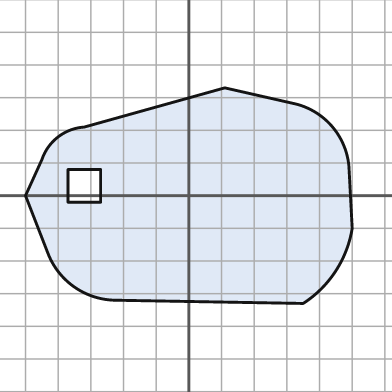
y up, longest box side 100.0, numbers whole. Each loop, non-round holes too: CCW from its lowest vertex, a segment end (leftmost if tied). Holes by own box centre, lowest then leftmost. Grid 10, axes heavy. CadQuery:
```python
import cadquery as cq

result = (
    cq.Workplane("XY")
    .moveTo(35.0, -33.0)
    .threePointArc((45.0, -23.0), (50.0, -10.0))
    .lineTo(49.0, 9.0)
    .threePointArc((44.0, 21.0), (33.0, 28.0))
    .lineTo(11.0, 33.0)
    .lineTo(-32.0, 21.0)
    .threePointArc((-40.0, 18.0), (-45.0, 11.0))
    .lineTo(-50.0, 0.0)
    .lineTo(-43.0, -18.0)
    .threePointArc((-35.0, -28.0), (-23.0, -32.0))
    .close()
    .moveTo(-37.0, -2.0)
    .lineTo(-27.0, -2.0)
    .lineTo(-27.0, 8.0)
    .lineTo(-37.0, 8.0)
    .close()
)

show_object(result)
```